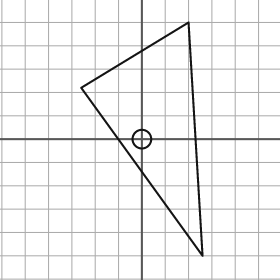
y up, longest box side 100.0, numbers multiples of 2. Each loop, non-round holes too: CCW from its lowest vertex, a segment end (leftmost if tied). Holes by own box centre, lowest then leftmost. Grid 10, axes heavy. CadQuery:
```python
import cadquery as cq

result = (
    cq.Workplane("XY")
    .moveTo(26.0, -50.0)
    .lineTo(20.0, 50.0)
    .lineTo(-26.0, 22.0)
    .close()
    .moveTo(0.0, 0.0)
    .circle(4.0)
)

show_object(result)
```